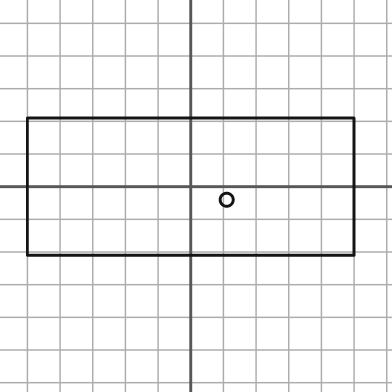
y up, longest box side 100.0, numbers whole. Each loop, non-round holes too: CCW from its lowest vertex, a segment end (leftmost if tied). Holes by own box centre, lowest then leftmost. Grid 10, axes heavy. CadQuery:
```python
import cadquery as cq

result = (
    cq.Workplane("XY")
    .moveTo(-50.0, -21.0)
    .lineTo(50.0, -21.0)
    .lineTo(50.0, 21.0)
    .lineTo(-50.0, 21.0)
    .close()
    .moveTo(11.0, -4.0)
    .circle(2.0)
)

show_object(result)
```